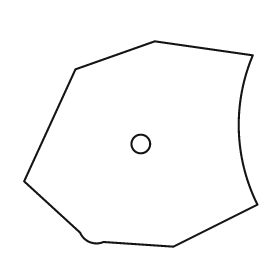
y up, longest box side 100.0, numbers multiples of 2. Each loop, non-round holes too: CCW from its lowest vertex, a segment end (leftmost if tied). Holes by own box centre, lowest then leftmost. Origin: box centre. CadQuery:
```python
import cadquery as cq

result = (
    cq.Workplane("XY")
    .moveTo(14.0, -44.0)
    .lineTo(50.0, -26.0)
    .threePointArc((42.0, 6.0), (48.0, 38.0))
    .lineTo(6.0, 44.0)
    .lineTo(-28.0, 32.0)
    .lineTo(-50.0, -16.0)
    .lineTo(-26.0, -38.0)
    .threePointArc((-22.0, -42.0), (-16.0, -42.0))
    .close()
    .moveTo(0.0, 0.0)
    .circle(4.0)
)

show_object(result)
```